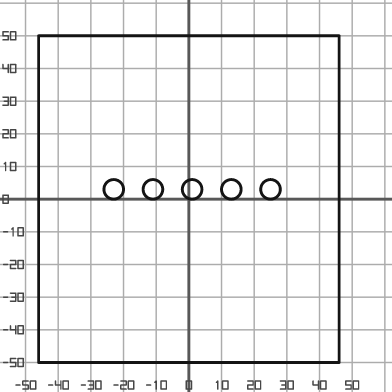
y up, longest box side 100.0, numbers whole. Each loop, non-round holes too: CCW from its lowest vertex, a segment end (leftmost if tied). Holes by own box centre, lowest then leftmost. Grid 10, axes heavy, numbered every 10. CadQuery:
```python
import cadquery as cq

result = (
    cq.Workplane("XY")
    .moveTo(-46.0, -50.0)
    .lineTo(46.0, -50.0)
    .lineTo(46.0, 50.0)
    .lineTo(-46.0, 50.0)
    .close()
    .moveTo(-23.0, 3.0)
    .circle(3.0)
    .moveTo(-11.0, 3.0)
    .circle(3.0)
    .moveTo(1.0, 3.0)
    .circle(3.0)
    .moveTo(13.0, 3.0)
    .circle(3.0)
    .moveTo(25.0, 3.0)
    .circle(3.0)
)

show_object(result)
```